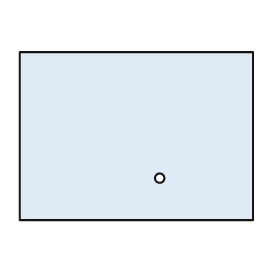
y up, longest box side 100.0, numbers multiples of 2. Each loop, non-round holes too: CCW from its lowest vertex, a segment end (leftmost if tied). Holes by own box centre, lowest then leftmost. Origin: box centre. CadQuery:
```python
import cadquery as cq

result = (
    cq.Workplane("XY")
    .moveTo(-50.0, -36.0)
    .lineTo(50.0, -36.0)
    .lineTo(50.0, 36.0)
    .lineTo(-50.0, 36.0)
    .close()
    .moveTo(10.0, -18.0)
    .circle(2.0)
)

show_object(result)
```